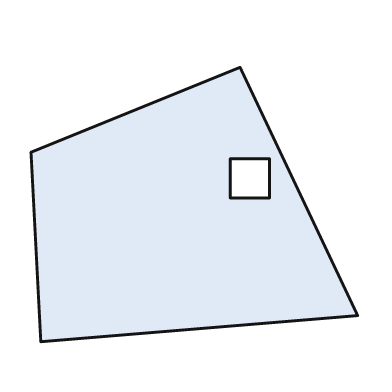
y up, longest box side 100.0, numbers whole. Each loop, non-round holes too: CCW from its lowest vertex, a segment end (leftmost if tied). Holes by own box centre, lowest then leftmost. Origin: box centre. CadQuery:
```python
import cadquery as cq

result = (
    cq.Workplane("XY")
    .moveTo(-47.0, -42.0)
    .lineTo(50.0, -34.0)
    .lineTo(14.0, 42.0)
    .lineTo(-50.0, 16.0)
    .close()
    .moveTo(11.0, 2.0)
    .lineTo(23.0, 2.0)
    .lineTo(23.0, 14.0)
    .lineTo(11.0, 14.0)
    .close()
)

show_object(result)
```